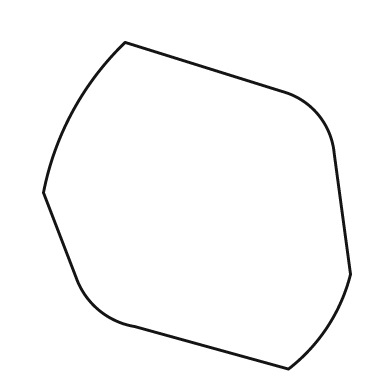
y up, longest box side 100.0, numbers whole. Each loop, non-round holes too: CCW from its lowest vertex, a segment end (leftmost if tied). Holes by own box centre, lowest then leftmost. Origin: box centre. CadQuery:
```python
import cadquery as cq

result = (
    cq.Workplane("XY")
    .moveTo(28.0, -50.0)
    .threePointArc((40.0, -37.0), (47.0, -21.0))
    .lineTo(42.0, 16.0)
    .threePointArc((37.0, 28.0), (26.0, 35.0))
    .lineTo(-22.0, 50.0)
    .threePointArc((-38.0, 29.0), (-47.0, 4.0))
    .lineTo(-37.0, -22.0)
    .threePointArc((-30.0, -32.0), (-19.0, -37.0))
    .close()
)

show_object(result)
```